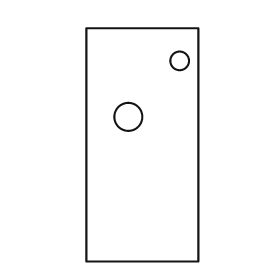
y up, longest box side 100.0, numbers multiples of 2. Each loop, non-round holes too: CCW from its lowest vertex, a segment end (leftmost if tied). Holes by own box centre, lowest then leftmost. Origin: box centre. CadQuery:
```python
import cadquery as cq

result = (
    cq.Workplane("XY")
    .moveTo(-24.0, -50.0)
    .lineTo(24.0, -50.0)
    .lineTo(24.0, 50.0)
    .lineTo(-24.0, 50.0)
    .close()
    .moveTo(-6.0, 12.0)
    .circle(6.0)
    .moveTo(16.0, 36.0)
    .circle(4.0)
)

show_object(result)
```